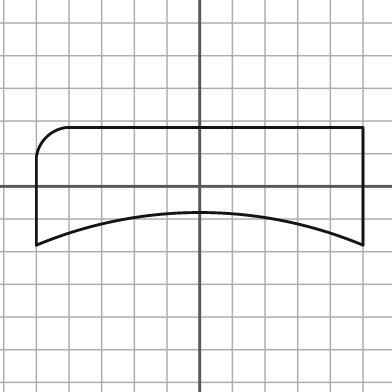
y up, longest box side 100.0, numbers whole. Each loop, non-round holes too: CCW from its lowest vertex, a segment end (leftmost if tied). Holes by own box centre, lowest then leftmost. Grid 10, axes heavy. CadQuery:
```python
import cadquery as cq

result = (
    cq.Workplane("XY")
    .moveTo(-50.0, -18.0)
    .threePointArc((0.0, -8.0), (50.0, -18.0))
    .lineTo(50.0, 18.0)
    .lineTo(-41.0, 18.0)
    .threePointArc((-47.0, 15.0), (-50.0, 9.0))
    .close()
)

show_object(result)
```